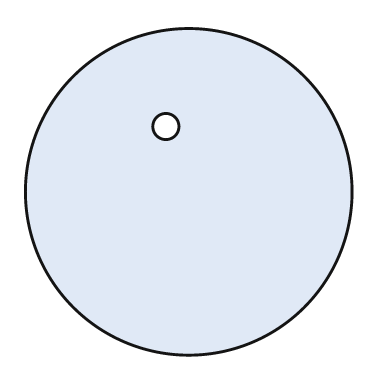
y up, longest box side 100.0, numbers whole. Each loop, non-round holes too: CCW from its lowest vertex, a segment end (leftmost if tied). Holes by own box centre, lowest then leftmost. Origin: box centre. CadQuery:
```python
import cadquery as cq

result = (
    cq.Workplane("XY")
    .moveTo(0.0, 0.0)
    .circle(50.0)
    .moveTo(-7.0, 20.0)
    .circle(4.0)
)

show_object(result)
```